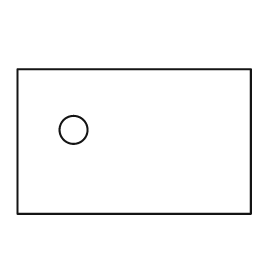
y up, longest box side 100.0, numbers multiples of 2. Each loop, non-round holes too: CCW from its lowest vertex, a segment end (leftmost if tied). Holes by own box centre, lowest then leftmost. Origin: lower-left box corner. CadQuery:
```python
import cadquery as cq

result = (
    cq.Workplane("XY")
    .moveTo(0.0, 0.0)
    .lineTo(100.0, 0.0)
    .lineTo(100.0, 62.0)
    .lineTo(0.0, 62.0)
    .close()
    .moveTo(24.0, 36.0)
    .circle(6.0)
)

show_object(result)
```